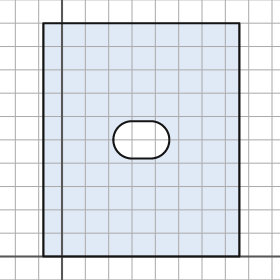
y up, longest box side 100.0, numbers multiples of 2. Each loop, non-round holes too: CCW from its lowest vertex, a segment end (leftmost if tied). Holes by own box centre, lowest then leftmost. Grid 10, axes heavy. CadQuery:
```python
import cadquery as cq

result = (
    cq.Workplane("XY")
    .moveTo(-8.0, 0.0)
    .lineTo(76.0, 0.0)
    .lineTo(76.0, 100.0)
    .lineTo(-8.0, 100.0)
    .close()
    .moveTo(30.0, 42.0)
    .lineTo(38.0, 42.0)
    .threePointArc((46.0, 50.0), (38.0, 58.0))
    .lineTo(30.0, 58.0)
    .threePointArc((22.0, 50.0), (30.0, 42.0))
    .close()
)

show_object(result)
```